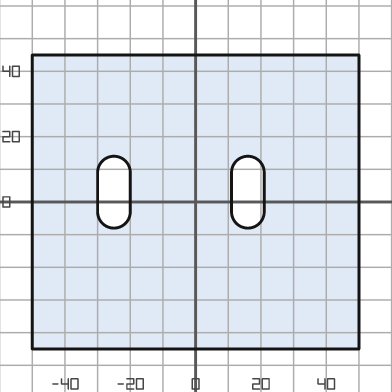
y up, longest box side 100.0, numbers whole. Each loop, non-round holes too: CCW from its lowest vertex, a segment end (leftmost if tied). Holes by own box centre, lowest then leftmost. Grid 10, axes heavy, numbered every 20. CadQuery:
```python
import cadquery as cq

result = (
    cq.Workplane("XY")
    .moveTo(-50.0, -45.0)
    .lineTo(50.0, -45.0)
    .lineTo(50.0, 45.0)
    .lineTo(-50.0, 45.0)
    .close()
    .moveTo(-30.0, -3.0)
    .threePointArc((-25.0, -8.0), (-20.0, -3.0))
    .lineTo(-20.0, 9.0)
    .threePointArc((-25.0, 14.0), (-30.0, 9.0))
    .close()
    .moveTo(11.0, -3.0)
    .threePointArc((16.0, -8.0), (21.0, -3.0))
    .lineTo(21.0, 9.0)
    .threePointArc((16.0, 14.0), (11.0, 9.0))
    .close()
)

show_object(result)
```